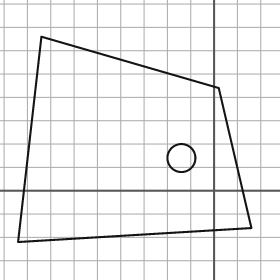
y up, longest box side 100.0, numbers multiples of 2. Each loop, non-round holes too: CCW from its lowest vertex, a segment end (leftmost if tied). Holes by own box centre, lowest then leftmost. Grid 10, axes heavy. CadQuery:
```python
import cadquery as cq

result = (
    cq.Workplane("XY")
    .moveTo(-84.0, -22.0)
    .lineTo(16.0, -16.0)
    .lineTo(2.0, 44.0)
    .lineTo(-74.0, 66.0)
    .close()
    .moveTo(-14.0, 14.0)
    .circle(6.0)
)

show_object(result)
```